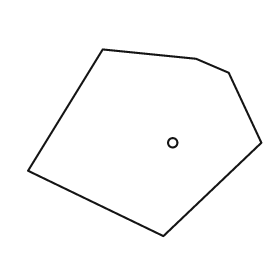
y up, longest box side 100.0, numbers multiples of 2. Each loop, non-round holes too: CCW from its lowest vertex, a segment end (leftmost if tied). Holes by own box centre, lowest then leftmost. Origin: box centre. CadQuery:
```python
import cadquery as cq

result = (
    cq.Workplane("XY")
    .moveTo(8.0, -40.0)
    .lineTo(50.0, 0.0)
    .lineTo(36.0, 30.0)
    .lineTo(22.0, 36.0)
    .lineTo(-18.0, 40.0)
    .lineTo(-50.0, -12.0)
    .close()
    .moveTo(12.0, 0.0)
    .circle(2.0)
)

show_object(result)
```